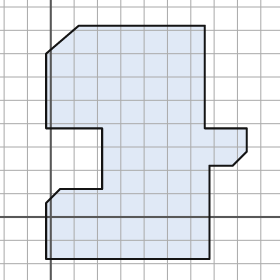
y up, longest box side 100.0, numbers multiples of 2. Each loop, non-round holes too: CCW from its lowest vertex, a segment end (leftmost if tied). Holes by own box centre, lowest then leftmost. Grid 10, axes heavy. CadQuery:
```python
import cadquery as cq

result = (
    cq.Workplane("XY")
    .moveTo(-2.0, -18.0)
    .lineTo(68.0, -18.0)
    .lineTo(68.0, 22.0)
    .lineTo(78.0, 22.0)
    .lineTo(84.0, 28.0)
    .lineTo(84.0, 38.0)
    .lineTo(66.0, 38.0)
    .lineTo(66.0, 82.0)
    .lineTo(12.0, 82.0)
    .lineTo(-2.0, 70.0)
    .lineTo(-2.0, 38.0)
    .lineTo(22.0, 38.0)
    .lineTo(22.0, 12.0)
    .lineTo(4.0, 12.0)
    .lineTo(-2.0, 6.0)
    .close()
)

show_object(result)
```